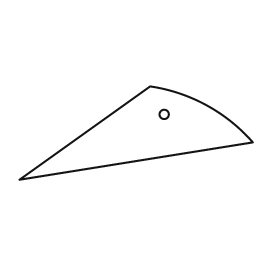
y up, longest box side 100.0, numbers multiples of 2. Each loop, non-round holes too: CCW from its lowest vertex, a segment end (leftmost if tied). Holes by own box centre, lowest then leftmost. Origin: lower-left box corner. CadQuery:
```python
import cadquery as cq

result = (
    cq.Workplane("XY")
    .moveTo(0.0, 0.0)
    .lineTo(100.0, 16.0)
    .threePointArc((80.0, 32.0), (56.0, 40.0))
    .close()
    .moveTo(62.0, 28.0)
    .circle(2.0)
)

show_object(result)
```